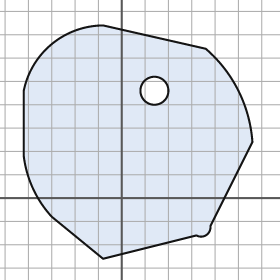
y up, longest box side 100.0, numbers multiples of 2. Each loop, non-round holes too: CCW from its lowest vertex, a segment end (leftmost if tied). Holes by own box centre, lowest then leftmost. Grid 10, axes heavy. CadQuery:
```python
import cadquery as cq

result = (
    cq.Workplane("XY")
    .moveTo(-8.0, -26.0)
    .lineTo(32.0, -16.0)
    .threePointArc((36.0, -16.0), (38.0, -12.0))
    .lineTo(56.0, 24.0)
    .threePointArc((50.0, 46.0), (36.0, 64.0))
    .lineTo(-8.0, 74.0)
    .threePointArc((-30.0, 66.0), (-42.0, 46.0))
    .lineTo(-42.0, 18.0)
    .threePointArc((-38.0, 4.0), (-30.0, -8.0))
    .close()
    .moveTo(14.0, 46.0)
    .circle(6.0)
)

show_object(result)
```